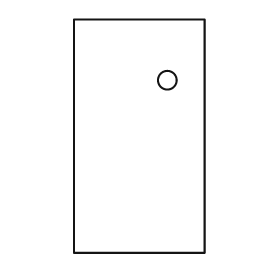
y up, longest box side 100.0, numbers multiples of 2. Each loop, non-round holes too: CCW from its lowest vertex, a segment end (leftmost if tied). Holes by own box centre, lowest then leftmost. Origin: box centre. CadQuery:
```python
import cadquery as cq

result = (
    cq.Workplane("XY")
    .moveTo(-28.0, -50.0)
    .lineTo(28.0, -50.0)
    .lineTo(28.0, 50.0)
    .lineTo(-28.0, 50.0)
    .close()
    .moveTo(12.0, 24.0)
    .circle(4.0)
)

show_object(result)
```